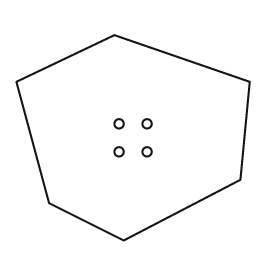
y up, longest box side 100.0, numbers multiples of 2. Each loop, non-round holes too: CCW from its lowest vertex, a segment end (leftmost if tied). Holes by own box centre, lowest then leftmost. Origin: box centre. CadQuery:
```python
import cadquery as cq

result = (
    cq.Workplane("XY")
    .moveTo(-4.0, -44.0)
    .lineTo(46.0, -18.0)
    .lineTo(50.0, 24.0)
    .lineTo(-8.0, 44.0)
    .lineTo(-50.0, 24.0)
    .lineTo(-36.0, -28.0)
    .close()
    .moveTo(-6.0, -6.0)
    .circle(2.0)
    .moveTo(6.0, -6.0)
    .circle(2.0)
    .moveTo(-6.0, 6.0)
    .circle(2.0)
    .moveTo(6.0, 6.0)
    .circle(2.0)
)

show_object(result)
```